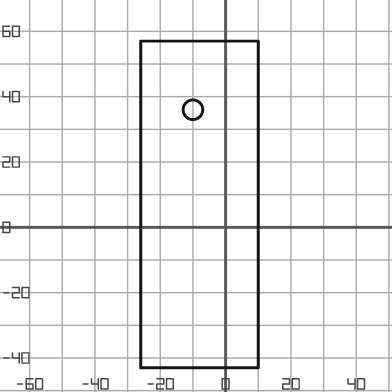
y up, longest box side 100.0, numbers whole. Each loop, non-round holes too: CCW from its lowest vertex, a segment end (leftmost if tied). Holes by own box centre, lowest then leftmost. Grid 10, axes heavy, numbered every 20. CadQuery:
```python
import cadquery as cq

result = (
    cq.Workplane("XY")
    .moveTo(-26.0, -43.0)
    .lineTo(10.0, -43.0)
    .lineTo(10.0, 57.0)
    .lineTo(-26.0, 57.0)
    .close()
    .moveTo(-10.0, 36.0)
    .circle(3.0)
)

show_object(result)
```